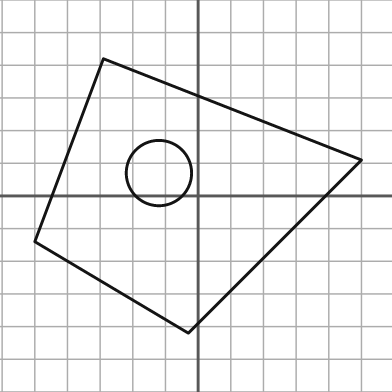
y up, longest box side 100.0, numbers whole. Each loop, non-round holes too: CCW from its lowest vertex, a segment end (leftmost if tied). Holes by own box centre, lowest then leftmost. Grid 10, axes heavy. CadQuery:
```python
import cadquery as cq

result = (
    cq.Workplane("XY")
    .moveTo(-3.0, -42.0)
    .lineTo(50.0, 11.0)
    .lineTo(-29.0, 42.0)
    .lineTo(-50.0, -14.0)
    .close()
    .moveTo(-12.0, 7.0)
    .circle(10.0)
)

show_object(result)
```